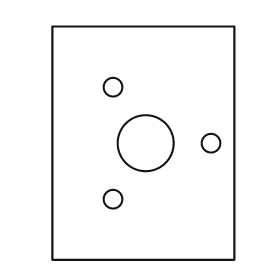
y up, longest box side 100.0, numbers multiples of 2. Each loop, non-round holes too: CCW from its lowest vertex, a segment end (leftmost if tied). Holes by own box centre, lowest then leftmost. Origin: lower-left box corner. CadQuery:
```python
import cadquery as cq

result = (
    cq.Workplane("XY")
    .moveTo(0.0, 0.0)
    .lineTo(78.0, 0.0)
    .lineTo(78.0, 100.0)
    .lineTo(0.0, 100.0)
    .close()
    .moveTo(26.0, 26.0)
    .circle(4.0)
    .moveTo(40.0, 50.0)
    .circle(12.0)
    .moveTo(68.0, 50.0)
    .circle(4.0)
    .moveTo(26.0, 74.0)
    .circle(4.0)
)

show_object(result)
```